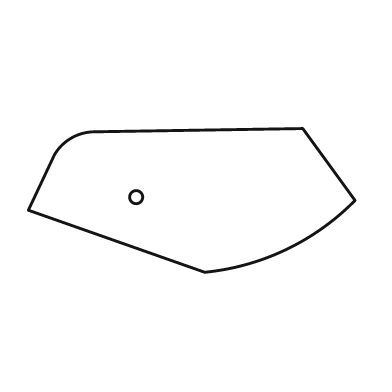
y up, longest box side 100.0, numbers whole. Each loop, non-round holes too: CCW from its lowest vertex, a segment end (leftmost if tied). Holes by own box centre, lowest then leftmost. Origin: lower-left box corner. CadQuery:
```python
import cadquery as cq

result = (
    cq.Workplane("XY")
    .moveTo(54.0, 0.0)
    .threePointArc((79.0, 7.0), (100.0, 22.0))
    .lineTo(84.0, 44.0)
    .lineTo(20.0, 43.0)
    .threePointArc((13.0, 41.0), (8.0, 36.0))
    .lineTo(0.0, 19.0)
    .close()
    .moveTo(33.0, 23.0)
    .circle(2.0)
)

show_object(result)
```